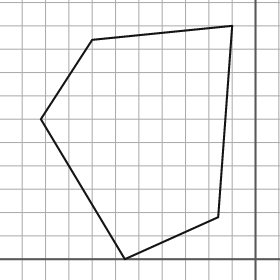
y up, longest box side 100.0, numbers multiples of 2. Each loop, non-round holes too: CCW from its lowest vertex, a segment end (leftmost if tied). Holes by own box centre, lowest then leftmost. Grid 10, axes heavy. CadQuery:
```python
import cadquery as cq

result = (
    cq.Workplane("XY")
    .moveTo(-56.0, 0.0)
    .lineTo(-16.0, 18.0)
    .lineTo(-10.0, 100.0)
    .lineTo(-70.0, 94.0)
    .lineTo(-92.0, 60.0)
    .close()
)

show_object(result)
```